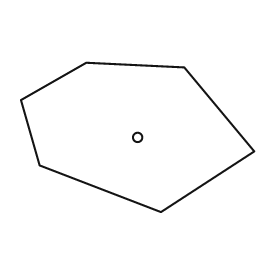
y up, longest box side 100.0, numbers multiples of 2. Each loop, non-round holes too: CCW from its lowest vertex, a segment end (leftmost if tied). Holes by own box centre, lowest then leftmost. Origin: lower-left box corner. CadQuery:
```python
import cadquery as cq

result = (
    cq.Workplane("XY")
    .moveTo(60.0, 0.0)
    .lineTo(100.0, 26.0)
    .lineTo(70.0, 62.0)
    .lineTo(28.0, 64.0)
    .lineTo(0.0, 48.0)
    .lineTo(8.0, 20.0)
    .close()
    .moveTo(50.0, 32.0)
    .circle(2.0)
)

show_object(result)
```